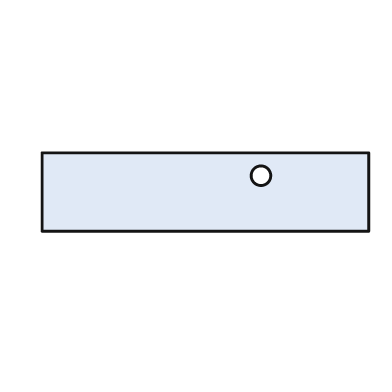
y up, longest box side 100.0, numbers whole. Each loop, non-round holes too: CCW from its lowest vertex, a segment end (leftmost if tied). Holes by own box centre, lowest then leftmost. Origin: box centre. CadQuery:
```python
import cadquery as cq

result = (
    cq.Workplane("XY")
    .moveTo(-50.0, -12.0)
    .lineTo(50.0, -12.0)
    .lineTo(50.0, 12.0)
    .lineTo(-50.0, 12.0)
    .close()
    .moveTo(17.0, 5.0)
    .circle(3.0)
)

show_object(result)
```